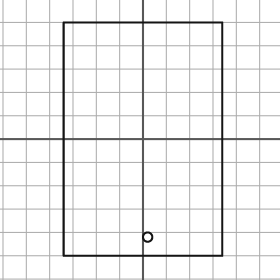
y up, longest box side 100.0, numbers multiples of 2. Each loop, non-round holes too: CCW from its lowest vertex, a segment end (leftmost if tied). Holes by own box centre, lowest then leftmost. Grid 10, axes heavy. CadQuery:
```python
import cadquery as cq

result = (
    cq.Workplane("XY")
    .moveTo(-34.0, -50.0)
    .lineTo(34.0, -50.0)
    .lineTo(34.0, 50.0)
    .lineTo(-34.0, 50.0)
    .close()
    .moveTo(2.0, -42.0)
    .circle(2.0)
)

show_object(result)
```